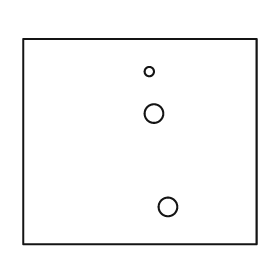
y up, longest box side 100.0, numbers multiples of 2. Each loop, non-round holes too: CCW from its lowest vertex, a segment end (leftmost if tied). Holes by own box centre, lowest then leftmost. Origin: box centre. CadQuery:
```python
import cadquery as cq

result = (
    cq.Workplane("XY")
    .moveTo(-50.0, -44.0)
    .lineTo(50.0, -44.0)
    .lineTo(50.0, 44.0)
    .lineTo(-50.0, 44.0)
    .close()
    .moveTo(12.0, -28.0)
    .circle(4.0)
    .moveTo(6.0, 12.0)
    .circle(4.0)
    .moveTo(4.0, 30.0)
    .circle(2.0)
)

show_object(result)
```